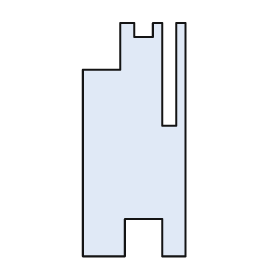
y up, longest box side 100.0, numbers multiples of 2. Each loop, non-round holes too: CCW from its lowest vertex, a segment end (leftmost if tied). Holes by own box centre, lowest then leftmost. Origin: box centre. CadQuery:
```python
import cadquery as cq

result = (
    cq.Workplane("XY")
    .moveTo(-22.0, -50.0)
    .lineTo(-4.0, -50.0)
    .lineTo(-4.0, -34.0)
    .lineTo(12.0, -34.0)
    .lineTo(12.0, -50.0)
    .lineTo(22.0, -50.0)
    .lineTo(22.0, 50.0)
    .lineTo(18.0, 50.0)
    .lineTo(18.0, 6.0)
    .lineTo(12.0, 6.0)
    .lineTo(12.0, 50.0)
    .lineTo(8.0, 50.0)
    .lineTo(8.0, 44.0)
    .lineTo(0.0, 44.0)
    .lineTo(0.0, 50.0)
    .lineTo(-6.0, 50.0)
    .lineTo(-6.0, 30.0)
    .lineTo(-22.0, 30.0)
    .close()
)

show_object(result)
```